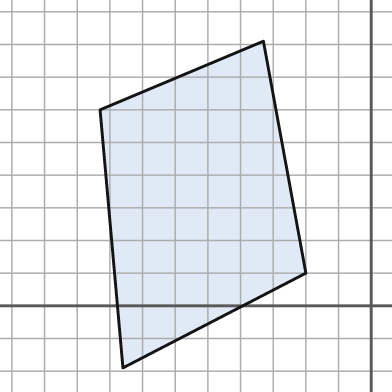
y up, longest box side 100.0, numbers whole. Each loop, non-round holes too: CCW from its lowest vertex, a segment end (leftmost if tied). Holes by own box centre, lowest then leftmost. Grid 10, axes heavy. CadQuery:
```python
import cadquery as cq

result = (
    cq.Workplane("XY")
    .moveTo(-76.0, -19.0)
    .lineTo(-20.0, 10.0)
    .lineTo(-33.0, 81.0)
    .lineTo(-83.0, 60.0)
    .close()
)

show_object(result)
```